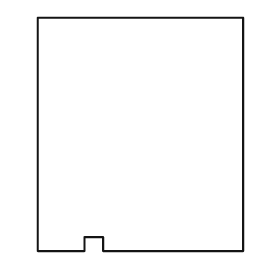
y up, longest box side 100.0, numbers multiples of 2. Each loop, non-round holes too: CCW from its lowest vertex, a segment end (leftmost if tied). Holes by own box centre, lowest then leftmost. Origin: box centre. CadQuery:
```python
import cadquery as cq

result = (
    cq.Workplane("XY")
    .moveTo(-44.0, -50.0)
    .lineTo(-24.0, -50.0)
    .lineTo(-24.0, -44.0)
    .lineTo(-16.0, -44.0)
    .lineTo(-16.0, -50.0)
    .lineTo(44.0, -50.0)
    .lineTo(44.0, 50.0)
    .lineTo(-44.0, 50.0)
    .close()
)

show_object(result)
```